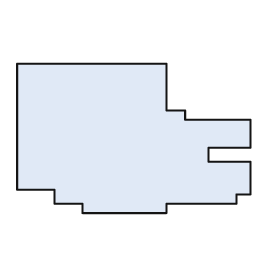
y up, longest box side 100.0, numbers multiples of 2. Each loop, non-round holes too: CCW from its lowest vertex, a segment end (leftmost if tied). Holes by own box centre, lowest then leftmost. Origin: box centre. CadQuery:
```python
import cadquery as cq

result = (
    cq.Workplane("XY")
    .moveTo(-22.0, -32.0)
    .lineTo(14.0, -32.0)
    .lineTo(14.0, -28.0)
    .lineTo(44.0, -28.0)
    .lineTo(44.0, -24.0)
    .lineTo(50.0, -24.0)
    .lineTo(50.0, -10.0)
    .lineTo(32.0, -10.0)
    .lineTo(32.0, -4.0)
    .lineTo(50.0, -4.0)
    .lineTo(50.0, 8.0)
    .lineTo(22.0, 8.0)
    .lineTo(22.0, 12.0)
    .lineTo(14.0, 12.0)
    .lineTo(14.0, 32.0)
    .lineTo(-50.0, 32.0)
    .lineTo(-50.0, -22.0)
    .lineTo(-34.0, -22.0)
    .lineTo(-34.0, -28.0)
    .lineTo(-22.0, -28.0)
    .close()
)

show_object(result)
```